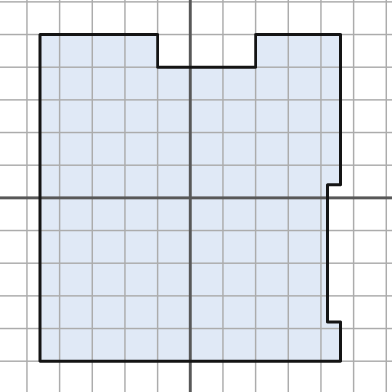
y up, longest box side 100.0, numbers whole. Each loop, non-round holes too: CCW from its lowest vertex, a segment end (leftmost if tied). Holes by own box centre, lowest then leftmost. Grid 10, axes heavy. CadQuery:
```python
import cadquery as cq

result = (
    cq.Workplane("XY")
    .moveTo(-46.0, -50.0)
    .lineTo(46.0, -50.0)
    .lineTo(46.0, -38.0)
    .lineTo(42.0, -38.0)
    .lineTo(42.0, 4.0)
    .lineTo(46.0, 4.0)
    .lineTo(46.0, 50.0)
    .lineTo(20.0, 50.0)
    .lineTo(20.0, 40.0)
    .lineTo(-10.0, 40.0)
    .lineTo(-10.0, 50.0)
    .lineTo(-46.0, 50.0)
    .close()
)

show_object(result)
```